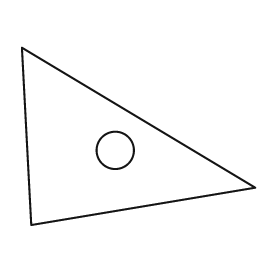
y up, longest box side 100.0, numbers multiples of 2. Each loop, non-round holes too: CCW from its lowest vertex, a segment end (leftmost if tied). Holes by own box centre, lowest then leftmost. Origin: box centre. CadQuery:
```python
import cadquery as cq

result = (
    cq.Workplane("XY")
    .moveTo(-46.0, -38.0)
    .lineTo(50.0, -22.0)
    .lineTo(-50.0, 38.0)
    .close()
    .moveTo(-10.0, -6.0)
    .circle(8.0)
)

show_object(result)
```